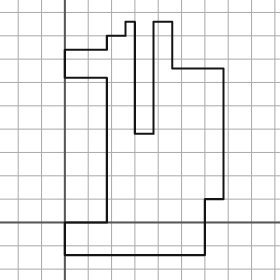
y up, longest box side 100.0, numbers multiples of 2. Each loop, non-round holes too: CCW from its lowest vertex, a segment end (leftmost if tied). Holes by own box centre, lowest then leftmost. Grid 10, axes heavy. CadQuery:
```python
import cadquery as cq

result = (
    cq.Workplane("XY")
    .moveTo(0.0, -14.0)
    .lineTo(60.0, -14.0)
    .lineTo(60.0, 10.0)
    .lineTo(68.0, 10.0)
    .lineTo(68.0, 66.0)
    .lineTo(46.0, 66.0)
    .lineTo(46.0, 86.0)
    .lineTo(38.0, 86.0)
    .lineTo(38.0, 38.0)
    .lineTo(30.0, 38.0)
    .lineTo(30.0, 86.0)
    .lineTo(26.0, 86.0)
    .lineTo(26.0, 80.0)
    .lineTo(18.0, 80.0)
    .lineTo(18.0, 74.0)
    .lineTo(0.0, 74.0)
    .lineTo(0.0, 62.0)
    .lineTo(18.0, 62.0)
    .lineTo(18.0, 0.0)
    .lineTo(0.0, 0.0)
    .close()
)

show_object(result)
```